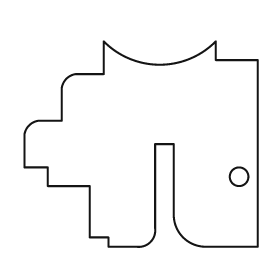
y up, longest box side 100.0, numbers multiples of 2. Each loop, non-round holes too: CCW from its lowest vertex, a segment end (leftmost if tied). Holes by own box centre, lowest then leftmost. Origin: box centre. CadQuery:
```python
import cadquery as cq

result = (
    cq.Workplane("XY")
    .moveTo(-14.0, -44.0)
    .lineTo(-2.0, -44.0)
    .threePointArc((4.0, -42.0), (6.0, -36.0))
    .lineTo(6.0, 0.0)
    .lineTo(14.0, 0.0)
    .lineTo(14.0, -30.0)
    .threePointArc((18.0, -40.0), (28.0, -44.0))
    .lineTo(50.0, -44.0)
    .lineTo(50.0, 36.0)
    .lineTo(32.0, 36.0)
    .lineTo(32.0, 44.0)
    .threePointArc((8.0, 34.0), (-16.0, 44.0))
    .lineTo(-16.0, 30.0)
    .lineTo(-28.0, 30.0)
    .threePointArc((-32.0, 28.0), (-34.0, 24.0))
    .lineTo(-34.0, 10.0)
    .lineTo(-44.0, 10.0)
    .threePointArc((-48.0, 8.0), (-50.0, 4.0))
    .lineTo(-50.0, -10.0)
    .lineTo(-40.0, -10.0)
    .lineTo(-40.0, -18.0)
    .lineTo(-22.0, -18.0)
    .lineTo(-22.0, -40.0)
    .lineTo(-14.0, -40.0)
    .close()
    .moveTo(42.0, -14.0)
    .circle(4.0)
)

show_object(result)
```